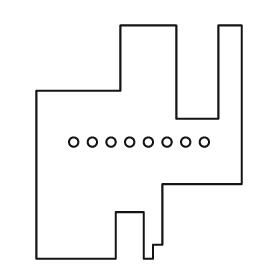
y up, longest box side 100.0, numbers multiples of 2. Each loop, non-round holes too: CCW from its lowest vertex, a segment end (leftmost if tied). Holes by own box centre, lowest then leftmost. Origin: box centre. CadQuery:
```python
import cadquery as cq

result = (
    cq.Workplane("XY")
    .moveTo(-44.0, -50.0)
    .lineTo(-10.0, -50.0)
    .lineTo(-10.0, -30.0)
    .lineTo(2.0, -30.0)
    .lineTo(2.0, -50.0)
    .lineTo(6.0, -50.0)
    .lineTo(6.0, -44.0)
    .lineTo(10.0, -44.0)
    .lineTo(10.0, -18.0)
    .lineTo(44.0, -18.0)
    .lineTo(44.0, 50.0)
    .lineTo(34.0, 50.0)
    .lineTo(34.0, 10.0)
    .lineTo(16.0, 10.0)
    .lineTo(16.0, 50.0)
    .lineTo(-8.0, 50.0)
    .lineTo(-8.0, 22.0)
    .lineTo(-44.0, 22.0)
    .close()
    .moveTo(-28.0, 0.0)
    .circle(2.0)
    .moveTo(-20.0, 0.0)
    .circle(2.0)
    .moveTo(-12.0, 0.0)
    .circle(2.0)
    .moveTo(-4.0, 0.0)
    .circle(2.0)
    .moveTo(4.0, 0.0)
    .circle(2.0)
    .moveTo(12.0, 0.0)
    .circle(2.0)
    .moveTo(20.0, 0.0)
    .circle(2.0)
    .moveTo(28.0, 0.0)
    .circle(2.0)
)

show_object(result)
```